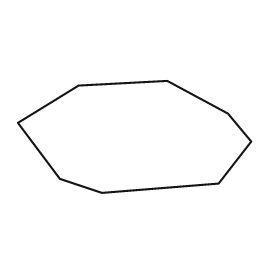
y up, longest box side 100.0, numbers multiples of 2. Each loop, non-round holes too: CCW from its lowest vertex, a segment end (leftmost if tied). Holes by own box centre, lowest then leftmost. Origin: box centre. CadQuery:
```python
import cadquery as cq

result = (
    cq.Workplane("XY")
    .moveTo(-14.0, -24.0)
    .lineTo(36.0, -20.0)
    .lineTo(50.0, -2.0)
    .lineTo(40.0, 10.0)
    .lineTo(14.0, 24.0)
    .lineTo(-24.0, 22.0)
    .lineTo(-50.0, 6.0)
    .lineTo(-32.0, -18.0)
    .close()
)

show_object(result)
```